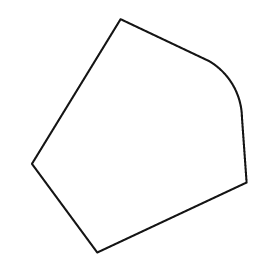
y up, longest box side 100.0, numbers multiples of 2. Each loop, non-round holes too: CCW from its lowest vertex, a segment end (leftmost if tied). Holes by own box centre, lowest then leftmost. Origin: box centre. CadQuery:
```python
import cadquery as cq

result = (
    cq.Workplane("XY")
    .moveTo(-18.0, -50.0)
    .lineTo(46.0, -20.0)
    .lineTo(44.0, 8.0)
    .threePointArc((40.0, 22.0), (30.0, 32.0))
    .lineTo(-8.0, 50.0)
    .lineTo(-46.0, -12.0)
    .close()
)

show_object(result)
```